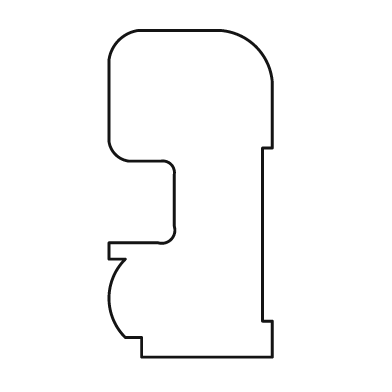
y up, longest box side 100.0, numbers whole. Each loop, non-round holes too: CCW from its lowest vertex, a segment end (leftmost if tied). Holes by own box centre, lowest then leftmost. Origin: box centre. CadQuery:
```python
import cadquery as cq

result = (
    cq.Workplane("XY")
    .moveTo(-15.0, -50.0)
    .lineTo(25.0, -50.0)
    .lineTo(25.0, -39.0)
    .lineTo(22.0, -39.0)
    .lineTo(22.0, 14.0)
    .lineTo(25.0, 14.0)
    .lineTo(25.0, 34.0)
    .threePointArc((20.0, 45.0), (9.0, 50.0))
    .lineTo(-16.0, 50.0)
    .threePointArc((-22.0, 47.0), (-25.0, 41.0))
    .lineTo(-25.0, 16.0)
    .threePointArc((-23.0, 12.0), (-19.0, 10.0))
    .lineTo(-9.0, 10.0)
    .threePointArc((-6.0, 9.0), (-5.0, 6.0))
    .lineTo(-5.0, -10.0)
    .threePointArc((-6.0, -14.0), (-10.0, -15.0))
    .lineTo(-25.0, -15.0)
    .lineTo(-25.0, -20.0)
    .lineTo(-20.0, -20.0)
    .threePointArc((-25.0, -32.0), (-20.0, -44.0))
    .lineTo(-15.0, -44.0)
    .close()
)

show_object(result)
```